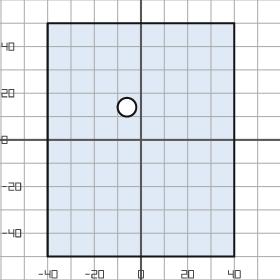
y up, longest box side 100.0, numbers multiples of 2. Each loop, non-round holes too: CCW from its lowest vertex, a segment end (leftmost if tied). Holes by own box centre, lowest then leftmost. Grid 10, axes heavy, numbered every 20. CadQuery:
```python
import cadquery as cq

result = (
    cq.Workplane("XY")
    .moveTo(-40.0, -50.0)
    .lineTo(40.0, -50.0)
    .lineTo(40.0, 50.0)
    .lineTo(-40.0, 50.0)
    .close()
    .moveTo(-6.0, 14.0)
    .circle(4.0)
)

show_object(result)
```